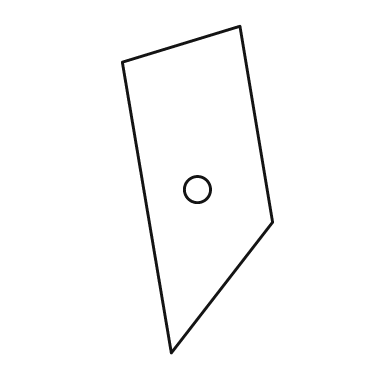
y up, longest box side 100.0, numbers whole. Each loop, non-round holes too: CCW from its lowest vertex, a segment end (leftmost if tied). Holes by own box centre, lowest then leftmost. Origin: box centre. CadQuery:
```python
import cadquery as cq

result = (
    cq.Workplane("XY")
    .moveTo(-8.0, -50.0)
    .lineTo(23.0, -10.0)
    .lineTo(13.0, 50.0)
    .lineTo(-23.0, 39.0)
    .close()
    .moveTo(0.0, 0.0)
    .circle(4.0)
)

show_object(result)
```